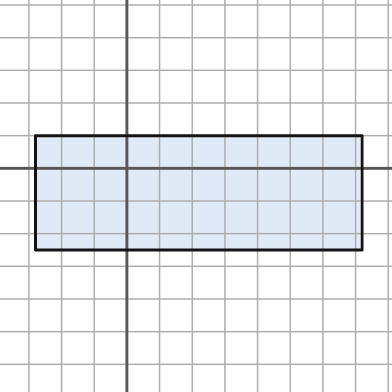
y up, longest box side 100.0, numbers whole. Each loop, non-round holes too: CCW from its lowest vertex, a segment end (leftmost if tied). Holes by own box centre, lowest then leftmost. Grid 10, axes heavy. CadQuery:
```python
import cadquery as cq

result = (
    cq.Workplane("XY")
    .moveTo(-28.0, -25.0)
    .lineTo(72.0, -25.0)
    .lineTo(72.0, 10.0)
    .lineTo(-28.0, 10.0)
    .close()
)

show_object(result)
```